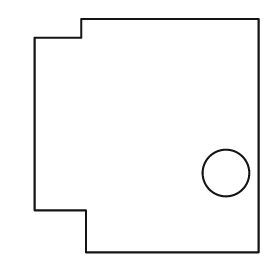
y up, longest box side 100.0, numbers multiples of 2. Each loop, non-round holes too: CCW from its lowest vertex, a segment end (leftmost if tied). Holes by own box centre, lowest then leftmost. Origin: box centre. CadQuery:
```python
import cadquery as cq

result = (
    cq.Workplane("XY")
    .moveTo(-26.0, -50.0)
    .lineTo(48.0, -50.0)
    .lineTo(48.0, 50.0)
    .lineTo(-28.0, 50.0)
    .lineTo(-28.0, 42.0)
    .lineTo(-48.0, 42.0)
    .lineTo(-48.0, -32.0)
    .lineTo(-26.0, -32.0)
    .close()
    .moveTo(34.0, -16.0)
    .circle(10.0)
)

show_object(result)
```